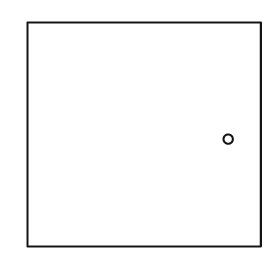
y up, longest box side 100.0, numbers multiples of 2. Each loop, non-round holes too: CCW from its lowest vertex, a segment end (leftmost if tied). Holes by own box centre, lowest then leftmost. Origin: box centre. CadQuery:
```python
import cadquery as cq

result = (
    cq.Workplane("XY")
    .moveTo(-50.0, -48.0)
    .lineTo(50.0, -48.0)
    .lineTo(50.0, 48.0)
    .lineTo(-50.0, 48.0)
    .close()
    .moveTo(36.0, -2.0)
    .circle(2.0)
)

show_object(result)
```